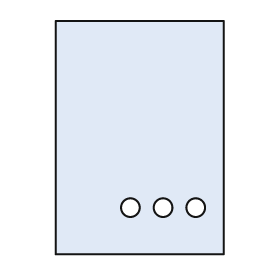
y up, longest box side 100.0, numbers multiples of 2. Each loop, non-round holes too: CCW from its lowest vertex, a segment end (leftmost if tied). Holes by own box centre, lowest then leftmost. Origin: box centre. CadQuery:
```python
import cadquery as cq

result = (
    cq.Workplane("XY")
    .moveTo(-36.0, -50.0)
    .lineTo(36.0, -50.0)
    .lineTo(36.0, 50.0)
    .lineTo(-36.0, 50.0)
    .close()
    .moveTo(-4.0, -30.0)
    .circle(4.0)
    .moveTo(10.0, -30.0)
    .circle(4.0)
    .moveTo(24.0, -30.0)
    .circle(4.0)
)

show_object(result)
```